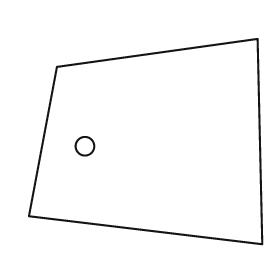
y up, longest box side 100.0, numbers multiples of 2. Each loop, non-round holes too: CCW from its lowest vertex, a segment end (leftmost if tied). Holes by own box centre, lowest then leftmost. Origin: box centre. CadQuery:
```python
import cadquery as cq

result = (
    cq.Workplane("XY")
    .moveTo(50.0, -44.0)
    .lineTo(48.0, 44.0)
    .lineTo(-38.0, 32.0)
    .lineTo(-50.0, -32.0)
    .close()
    .moveTo(-26.0, -2.0)
    .circle(4.0)
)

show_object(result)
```